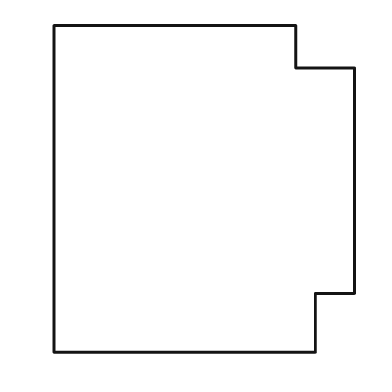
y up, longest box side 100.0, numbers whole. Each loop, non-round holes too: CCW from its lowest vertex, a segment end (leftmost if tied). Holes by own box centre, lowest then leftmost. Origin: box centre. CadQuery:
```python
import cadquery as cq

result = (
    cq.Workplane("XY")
    .moveTo(-46.0, -50.0)
    .lineTo(34.0, -50.0)
    .lineTo(34.0, -32.0)
    .lineTo(46.0, -32.0)
    .lineTo(46.0, 37.0)
    .lineTo(28.0, 37.0)
    .lineTo(28.0, 50.0)
    .lineTo(-46.0, 50.0)
    .close()
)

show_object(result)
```